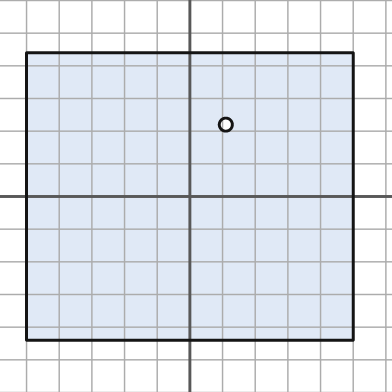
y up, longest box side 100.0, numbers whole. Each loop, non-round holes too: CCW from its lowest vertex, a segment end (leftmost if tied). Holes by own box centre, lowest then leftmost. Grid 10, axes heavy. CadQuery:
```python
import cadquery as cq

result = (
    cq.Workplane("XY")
    .moveTo(-50.0, -44.0)
    .lineTo(50.0, -44.0)
    .lineTo(50.0, 44.0)
    .lineTo(-50.0, 44.0)
    .close()
    .moveTo(11.0, 22.0)
    .circle(2.0)
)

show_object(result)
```